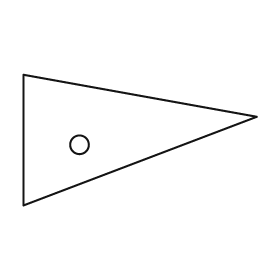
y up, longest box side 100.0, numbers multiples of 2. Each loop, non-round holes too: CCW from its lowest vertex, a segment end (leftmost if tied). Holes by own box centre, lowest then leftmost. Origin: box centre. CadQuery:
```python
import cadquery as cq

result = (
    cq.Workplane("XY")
    .moveTo(-50.0, -28.0)
    .lineTo(50.0, 10.0)
    .lineTo(-50.0, 28.0)
    .close()
    .moveTo(-26.0, -2.0)
    .circle(4.0)
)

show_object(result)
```